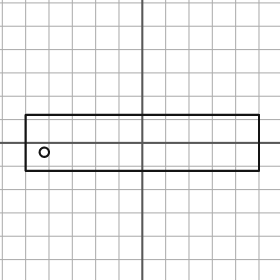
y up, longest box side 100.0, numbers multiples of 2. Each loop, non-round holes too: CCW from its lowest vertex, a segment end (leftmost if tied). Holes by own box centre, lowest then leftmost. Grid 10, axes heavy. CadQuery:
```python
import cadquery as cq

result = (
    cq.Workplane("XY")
    .moveTo(-50.0, -12.0)
    .lineTo(50.0, -12.0)
    .lineTo(50.0, 12.0)
    .lineTo(-50.0, 12.0)
    .close()
    .moveTo(-42.0, -4.0)
    .circle(2.0)
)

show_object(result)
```